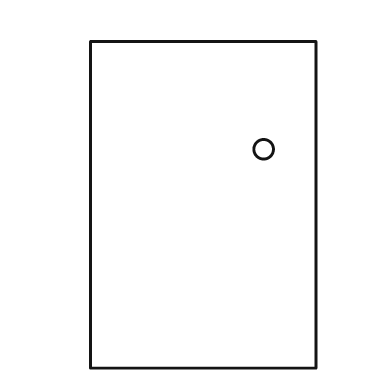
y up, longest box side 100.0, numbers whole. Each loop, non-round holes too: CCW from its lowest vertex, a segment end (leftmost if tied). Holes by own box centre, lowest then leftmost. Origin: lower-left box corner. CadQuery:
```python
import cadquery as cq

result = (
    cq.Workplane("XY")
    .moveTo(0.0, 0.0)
    .lineTo(69.0, 0.0)
    .lineTo(69.0, 100.0)
    .lineTo(0.0, 100.0)
    .close()
    .moveTo(53.0, 67.0)
    .circle(3.0)
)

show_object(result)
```